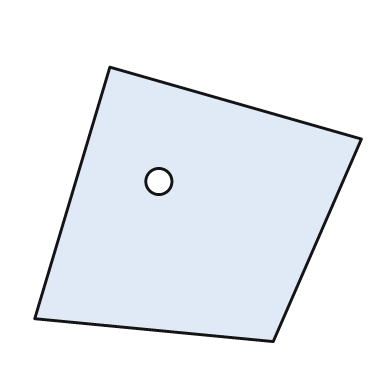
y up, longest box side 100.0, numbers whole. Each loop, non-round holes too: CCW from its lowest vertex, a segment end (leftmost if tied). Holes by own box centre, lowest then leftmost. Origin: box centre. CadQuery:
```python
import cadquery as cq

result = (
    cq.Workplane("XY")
    .moveTo(23.0, -42.0)
    .lineTo(50.0, 20.0)
    .lineTo(-27.0, 42.0)
    .lineTo(-50.0, -35.0)
    .close()
    .moveTo(-12.0, 7.0)
    .circle(4.0)
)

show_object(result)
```